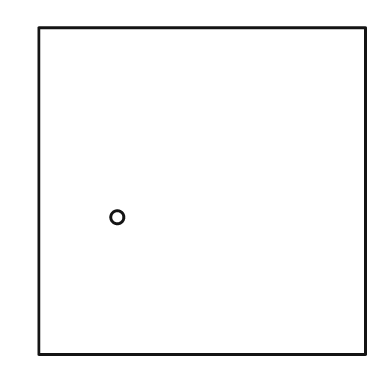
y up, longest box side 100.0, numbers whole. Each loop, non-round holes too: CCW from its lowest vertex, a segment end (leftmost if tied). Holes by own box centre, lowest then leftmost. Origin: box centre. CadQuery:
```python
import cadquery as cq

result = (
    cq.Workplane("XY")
    .moveTo(-50.0, -50.0)
    .lineTo(50.0, -50.0)
    .lineTo(50.0, 50.0)
    .lineTo(-50.0, 50.0)
    .close()
    .moveTo(-26.0, -8.0)
    .circle(2.0)
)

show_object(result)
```